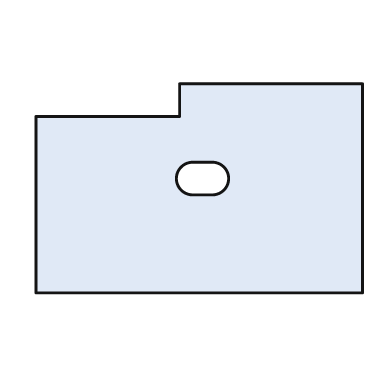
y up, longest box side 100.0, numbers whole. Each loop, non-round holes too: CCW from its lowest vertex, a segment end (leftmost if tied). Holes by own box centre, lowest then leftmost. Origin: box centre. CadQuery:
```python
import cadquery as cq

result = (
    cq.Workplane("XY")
    .moveTo(-50.0, -32.0)
    .lineTo(50.0, -32.0)
    .lineTo(50.0, 32.0)
    .lineTo(-6.0, 32.0)
    .lineTo(-6.0, 22.0)
    .lineTo(-50.0, 22.0)
    .close()
    .moveTo(-2.0, -2.0)
    .lineTo(4.0, -2.0)
    .threePointArc((9.0, 3.0), (4.0, 8.0))
    .lineTo(-2.0, 8.0)
    .threePointArc((-7.0, 3.0), (-2.0, -2.0))
    .close()
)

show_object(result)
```